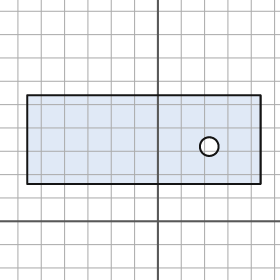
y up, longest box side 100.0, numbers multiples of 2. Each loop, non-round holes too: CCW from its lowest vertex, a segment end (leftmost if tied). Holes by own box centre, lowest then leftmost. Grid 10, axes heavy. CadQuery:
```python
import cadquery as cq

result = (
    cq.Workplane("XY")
    .moveTo(-56.0, 16.0)
    .lineTo(44.0, 16.0)
    .lineTo(44.0, 54.0)
    .lineTo(-56.0, 54.0)
    .close()
    .moveTo(22.0, 32.0)
    .circle(4.0)
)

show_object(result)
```